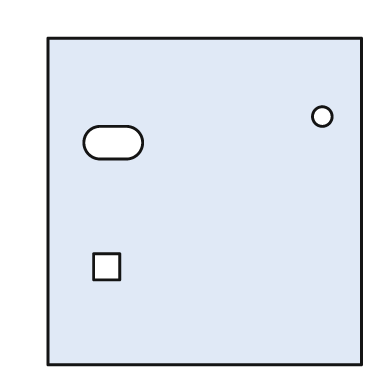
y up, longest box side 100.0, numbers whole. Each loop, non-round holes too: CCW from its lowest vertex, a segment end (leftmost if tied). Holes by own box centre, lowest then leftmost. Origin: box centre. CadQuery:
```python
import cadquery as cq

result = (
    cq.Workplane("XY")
    .moveTo(-48.0, -50.0)
    .lineTo(48.0, -50.0)
    .lineTo(48.0, 50.0)
    .lineTo(-48.0, 50.0)
    .close()
    .moveTo(-34.0, -24.0)
    .lineTo(-26.0, -24.0)
    .lineTo(-26.0, -16.0)
    .lineTo(-34.0, -16.0)
    .close()
    .moveTo(-32.0, 13.0)
    .lineTo(-24.0, 13.0)
    .threePointArc((-19.0, 18.0), (-24.0, 23.0))
    .lineTo(-32.0, 23.0)
    .threePointArc((-37.0, 18.0), (-32.0, 13.0))
    .close()
    .moveTo(36.0, 26.0)
    .circle(3.0)
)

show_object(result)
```